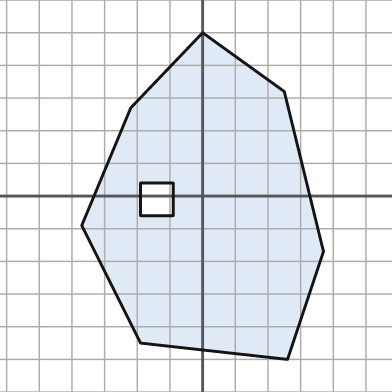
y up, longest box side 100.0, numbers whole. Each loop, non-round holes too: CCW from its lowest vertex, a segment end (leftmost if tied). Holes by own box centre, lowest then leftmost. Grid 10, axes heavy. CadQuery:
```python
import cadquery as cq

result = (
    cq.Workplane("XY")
    .moveTo(26.0, -50.0)
    .lineTo(37.0, -17.0)
    .lineTo(25.0, 32.0)
    .lineTo(0.0, 50.0)
    .lineTo(-22.0, 27.0)
    .lineTo(-37.0, -9.0)
    .lineTo(-19.0, -45.0)
    .close()
    .moveTo(-19.0, -6.0)
    .lineTo(-9.0, -6.0)
    .lineTo(-9.0, 4.0)
    .lineTo(-19.0, 4.0)
    .close()
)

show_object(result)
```